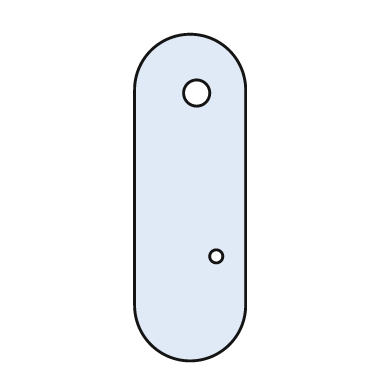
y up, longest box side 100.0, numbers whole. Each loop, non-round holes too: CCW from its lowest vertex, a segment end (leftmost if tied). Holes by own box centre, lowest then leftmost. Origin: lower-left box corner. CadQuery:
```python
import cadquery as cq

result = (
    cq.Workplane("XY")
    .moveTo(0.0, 17.0)
    .threePointArc((17.0, 0.0), (34.0, 17.0))
    .lineTo(34.0, 83.0)
    .threePointArc((17.0, 100.0), (0.0, 83.0))
    .close()
    .moveTo(25.0, 32.0)
    .circle(2.0)
    .moveTo(19.0, 82.0)
    .circle(4.0)
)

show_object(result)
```